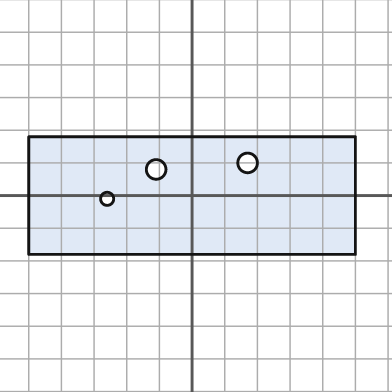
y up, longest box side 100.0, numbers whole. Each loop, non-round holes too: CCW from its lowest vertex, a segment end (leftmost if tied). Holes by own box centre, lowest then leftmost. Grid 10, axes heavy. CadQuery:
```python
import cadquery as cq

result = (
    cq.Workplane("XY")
    .moveTo(-50.0, -18.0)
    .lineTo(50.0, -18.0)
    .lineTo(50.0, 18.0)
    .lineTo(-50.0, 18.0)
    .close()
    .moveTo(-26.0, -1.0)
    .circle(2.0)
    .moveTo(-11.0, 8.0)
    .circle(3.0)
    .moveTo(17.0, 10.0)
    .circle(3.0)
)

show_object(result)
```